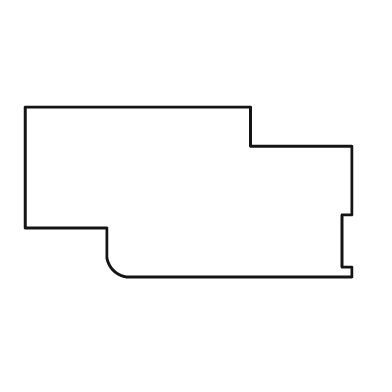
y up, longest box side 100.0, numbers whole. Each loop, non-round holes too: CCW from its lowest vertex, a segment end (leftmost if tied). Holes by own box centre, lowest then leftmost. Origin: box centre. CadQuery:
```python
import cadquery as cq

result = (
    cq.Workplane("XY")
    .moveTo(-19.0, -26.0)
    .lineTo(50.0, -26.0)
    .lineTo(50.0, -23.0)
    .lineTo(47.0, -23.0)
    .lineTo(47.0, -7.0)
    .lineTo(50.0, -7.0)
    .lineTo(50.0, 14.0)
    .lineTo(19.0, 14.0)
    .lineTo(19.0, 26.0)
    .lineTo(-50.0, 26.0)
    .lineTo(-50.0, -11.0)
    .lineTo(-25.0, -11.0)
    .lineTo(-25.0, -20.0)
    .threePointArc((-23.0, -24.0), (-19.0, -26.0))
    .close()
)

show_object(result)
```